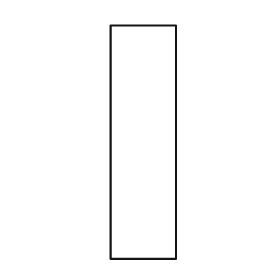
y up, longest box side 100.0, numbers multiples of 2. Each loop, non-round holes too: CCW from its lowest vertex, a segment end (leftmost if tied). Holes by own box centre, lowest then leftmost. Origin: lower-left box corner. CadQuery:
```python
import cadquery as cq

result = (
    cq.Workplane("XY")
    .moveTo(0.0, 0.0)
    .lineTo(28.0, 0.0)
    .lineTo(28.0, 100.0)
    .lineTo(0.0, 100.0)
    .close()
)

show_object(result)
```